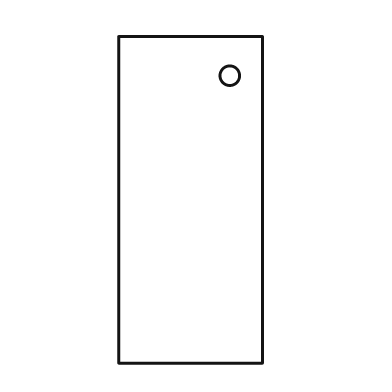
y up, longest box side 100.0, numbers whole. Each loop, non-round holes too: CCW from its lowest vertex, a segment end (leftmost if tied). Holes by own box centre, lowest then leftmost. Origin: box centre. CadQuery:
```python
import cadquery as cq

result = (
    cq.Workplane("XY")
    .moveTo(-22.0, -50.0)
    .lineTo(22.0, -50.0)
    .lineTo(22.0, 50.0)
    .lineTo(-22.0, 50.0)
    .close()
    .moveTo(12.0, 38.0)
    .circle(3.0)
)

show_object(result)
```